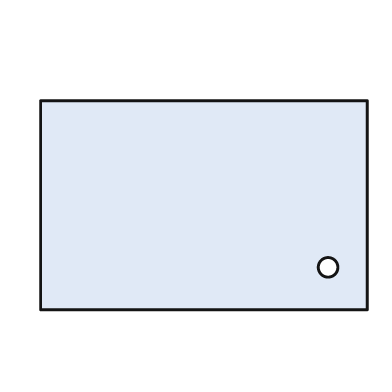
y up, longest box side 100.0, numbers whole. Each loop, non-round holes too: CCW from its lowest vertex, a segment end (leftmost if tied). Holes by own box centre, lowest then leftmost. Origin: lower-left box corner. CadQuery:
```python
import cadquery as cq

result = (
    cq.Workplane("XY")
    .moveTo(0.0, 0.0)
    .lineTo(100.0, 0.0)
    .lineTo(100.0, 64.0)
    .lineTo(0.0, 64.0)
    .close()
    .moveTo(88.0, 13.0)
    .circle(3.0)
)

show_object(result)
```